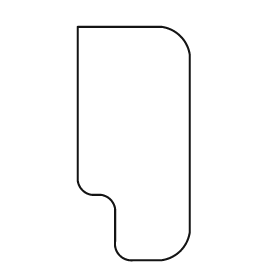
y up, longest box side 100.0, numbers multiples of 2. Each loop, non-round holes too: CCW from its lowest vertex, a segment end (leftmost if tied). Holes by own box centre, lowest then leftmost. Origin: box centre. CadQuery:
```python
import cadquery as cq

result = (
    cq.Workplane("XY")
    .moveTo(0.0, -50.0)
    .lineTo(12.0, -50.0)
    .threePointArc((20.0, -46.0), (24.0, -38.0))
    .lineTo(24.0, 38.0)
    .threePointArc((20.0, 46.0), (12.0, 50.0))
    .lineTo(-24.0, 50.0)
    .lineTo(-24.0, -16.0)
    .threePointArc((-22.0, -20.0), (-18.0, -22.0))
    .lineTo(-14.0, -22.0)
    .threePointArc((-10.0, -24.0), (-8.0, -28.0))
    .lineTo(-8.0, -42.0)
    .threePointArc((-6.0, -48.0), (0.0, -50.0))
    .close()
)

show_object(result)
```